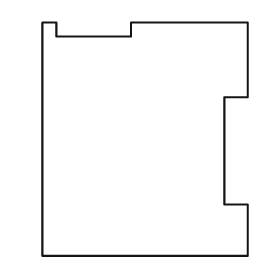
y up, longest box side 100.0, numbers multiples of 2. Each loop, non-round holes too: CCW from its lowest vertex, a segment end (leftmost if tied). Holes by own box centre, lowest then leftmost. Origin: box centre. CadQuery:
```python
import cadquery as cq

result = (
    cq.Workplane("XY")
    .moveTo(-44.0, -50.0)
    .lineTo(44.0, -50.0)
    .lineTo(44.0, -28.0)
    .lineTo(34.0, -28.0)
    .lineTo(34.0, 18.0)
    .lineTo(44.0, 18.0)
    .lineTo(44.0, 50.0)
    .lineTo(-6.0, 50.0)
    .lineTo(-6.0, 44.0)
    .lineTo(-38.0, 44.0)
    .lineTo(-38.0, 50.0)
    .lineTo(-44.0, 50.0)
    .close()
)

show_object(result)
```